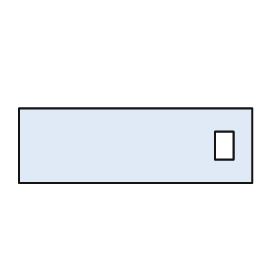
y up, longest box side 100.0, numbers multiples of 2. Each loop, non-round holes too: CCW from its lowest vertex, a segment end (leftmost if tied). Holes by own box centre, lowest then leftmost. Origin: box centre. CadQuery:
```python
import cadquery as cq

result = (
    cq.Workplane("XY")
    .moveTo(-50.0, -16.0)
    .lineTo(50.0, -16.0)
    .lineTo(50.0, 16.0)
    .lineTo(-50.0, 16.0)
    .close()
    .moveTo(34.0, -6.0)
    .lineTo(42.0, -6.0)
    .lineTo(42.0, 6.0)
    .lineTo(34.0, 6.0)
    .close()
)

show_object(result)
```